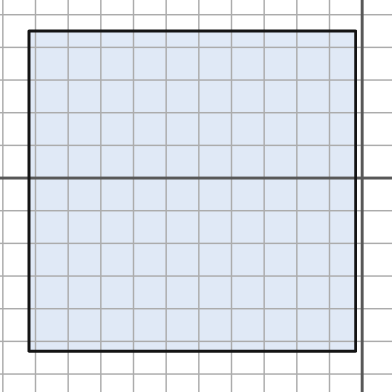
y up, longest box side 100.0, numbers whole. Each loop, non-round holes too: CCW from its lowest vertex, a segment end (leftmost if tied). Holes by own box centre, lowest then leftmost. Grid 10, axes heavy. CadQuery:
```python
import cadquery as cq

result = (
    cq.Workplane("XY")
    .moveTo(-102.0, -53.0)
    .lineTo(-2.0, -53.0)
    .lineTo(-2.0, 45.0)
    .lineTo(-102.0, 45.0)
    .close()
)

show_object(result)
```